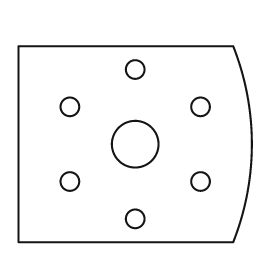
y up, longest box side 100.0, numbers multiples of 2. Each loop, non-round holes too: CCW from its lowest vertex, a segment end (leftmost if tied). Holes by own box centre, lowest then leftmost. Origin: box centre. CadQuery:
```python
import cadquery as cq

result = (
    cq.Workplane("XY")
    .moveTo(-50.0, -42.0)
    .lineTo(42.0, -42.0)
    .threePointArc((50.0, 0.0), (42.0, 42.0))
    .lineTo(-50.0, 42.0)
    .close()
    .moveTo(0.0, -32.0)
    .circle(4.0)
    .moveTo(-28.0, -16.0)
    .circle(4.0)
    .moveTo(28.0, -16.0)
    .circle(4.0)
    .moveTo(0.0, 0.0)
    .circle(10.0)
    .moveTo(-28.0, 16.0)
    .circle(4.0)
    .moveTo(28.0, 16.0)
    .circle(4.0)
    .moveTo(0.0, 32.0)
    .circle(4.0)
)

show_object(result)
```